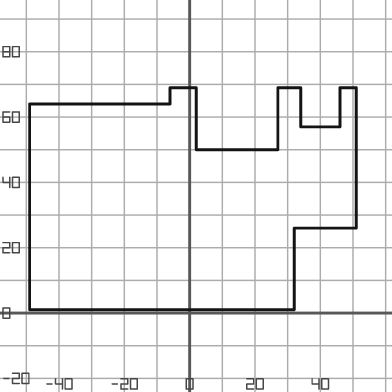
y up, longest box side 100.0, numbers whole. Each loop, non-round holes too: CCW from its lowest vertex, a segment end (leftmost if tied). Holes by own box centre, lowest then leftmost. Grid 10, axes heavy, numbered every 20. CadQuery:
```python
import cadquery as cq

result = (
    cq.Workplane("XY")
    .moveTo(-49.0, 1.0)
    .lineTo(32.0, 1.0)
    .lineTo(32.0, 26.0)
    .lineTo(51.0, 26.0)
    .lineTo(51.0, 69.0)
    .lineTo(46.0, 69.0)
    .lineTo(46.0, 57.0)
    .lineTo(34.0, 57.0)
    .lineTo(34.0, 69.0)
    .lineTo(27.0, 69.0)
    .lineTo(27.0, 50.0)
    .lineTo(2.0, 50.0)
    .lineTo(2.0, 69.0)
    .lineTo(-6.0, 69.0)
    .lineTo(-6.0, 64.0)
    .lineTo(-49.0, 64.0)
    .close()
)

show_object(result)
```